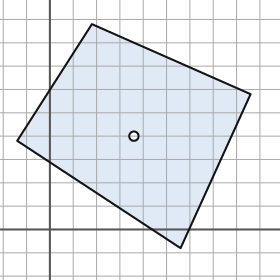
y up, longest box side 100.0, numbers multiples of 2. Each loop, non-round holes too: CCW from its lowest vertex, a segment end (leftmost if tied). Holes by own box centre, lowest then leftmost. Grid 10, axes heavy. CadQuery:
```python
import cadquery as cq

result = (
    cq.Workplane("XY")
    .moveTo(56.0, -8.0)
    .lineTo(86.0, 58.0)
    .lineTo(18.0, 88.0)
    .lineTo(-14.0, 38.0)
    .close()
    .moveTo(36.0, 40.0)
    .circle(2.0)
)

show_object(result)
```